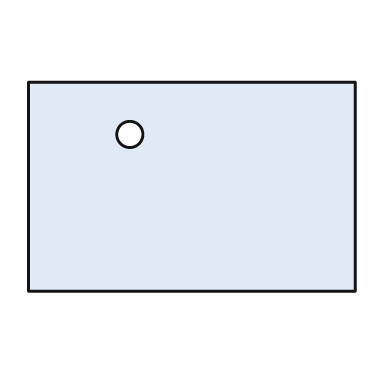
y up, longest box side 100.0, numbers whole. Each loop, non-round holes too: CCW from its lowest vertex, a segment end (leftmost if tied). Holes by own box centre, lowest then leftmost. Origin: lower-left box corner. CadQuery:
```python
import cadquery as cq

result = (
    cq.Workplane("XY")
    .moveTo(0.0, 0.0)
    .lineTo(100.0, 0.0)
    .lineTo(100.0, 64.0)
    .lineTo(0.0, 64.0)
    .close()
    .moveTo(31.0, 48.0)
    .circle(4.0)
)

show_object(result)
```